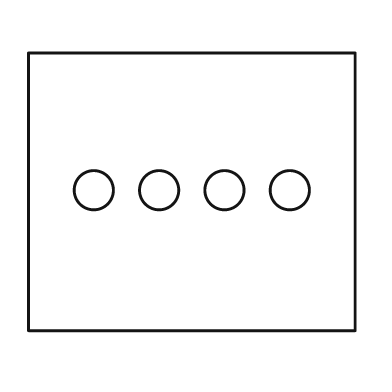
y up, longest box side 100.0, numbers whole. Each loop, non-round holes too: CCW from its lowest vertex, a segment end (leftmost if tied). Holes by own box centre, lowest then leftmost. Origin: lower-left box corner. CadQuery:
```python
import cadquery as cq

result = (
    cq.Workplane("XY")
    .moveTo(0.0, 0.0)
    .lineTo(100.0, 0.0)
    .lineTo(100.0, 85.0)
    .lineTo(0.0, 85.0)
    .close()
    .moveTo(20.0, 43.0)
    .circle(6.0)
    .moveTo(40.0, 43.0)
    .circle(6.0)
    .moveTo(60.0, 43.0)
    .circle(6.0)
    .moveTo(80.0, 43.0)
    .circle(6.0)
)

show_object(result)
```